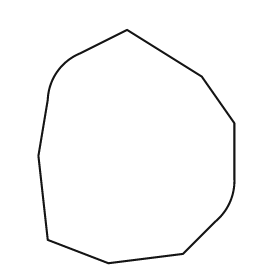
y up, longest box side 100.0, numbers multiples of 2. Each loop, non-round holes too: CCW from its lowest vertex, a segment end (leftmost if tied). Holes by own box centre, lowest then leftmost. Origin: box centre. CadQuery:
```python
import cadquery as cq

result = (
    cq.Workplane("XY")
    .moveTo(-12.0, -50.0)
    .lineTo(20.0, -46.0)
    .lineTo(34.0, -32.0)
    .threePointArc((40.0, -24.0), (42.0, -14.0))
    .lineTo(42.0, 10.0)
    .lineTo(28.0, 30.0)
    .lineTo(-4.0, 50.0)
    .lineTo(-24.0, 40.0)
    .threePointArc((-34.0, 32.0), (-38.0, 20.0))
    .lineTo(-42.0, -4.0)
    .lineTo(-38.0, -40.0)
    .close()
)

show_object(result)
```